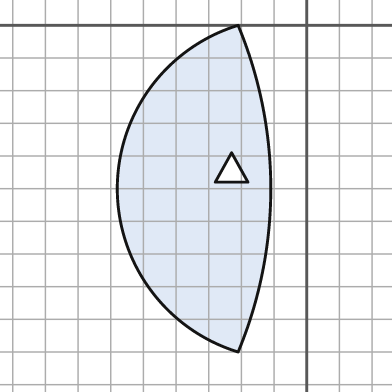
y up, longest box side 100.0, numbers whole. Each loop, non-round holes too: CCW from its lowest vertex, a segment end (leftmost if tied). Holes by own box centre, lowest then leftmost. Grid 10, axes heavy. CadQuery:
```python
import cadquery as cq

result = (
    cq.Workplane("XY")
    .moveTo(-21.0, -100.0)
    .threePointArc((-11.0, -50.0), (-21.0, 0.0))
    .threePointArc((-58.0, -50.0), (-21.0, -100.0))
    .close()
    .moveTo(-28.0, -48.0)
    .lineTo(-18.0, -48.0)
    .lineTo(-23.0, -39.0)
    .close()
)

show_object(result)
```